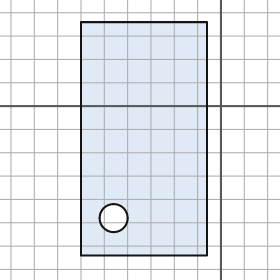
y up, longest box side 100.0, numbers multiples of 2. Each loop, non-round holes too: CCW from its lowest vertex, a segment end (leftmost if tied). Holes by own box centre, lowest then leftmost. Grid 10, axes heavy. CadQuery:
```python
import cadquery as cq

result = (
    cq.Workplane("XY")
    .moveTo(-60.0, -64.0)
    .lineTo(-6.0, -64.0)
    .lineTo(-6.0, 36.0)
    .lineTo(-60.0, 36.0)
    .close()
    .moveTo(-46.0, -48.0)
    .circle(6.0)
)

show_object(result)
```